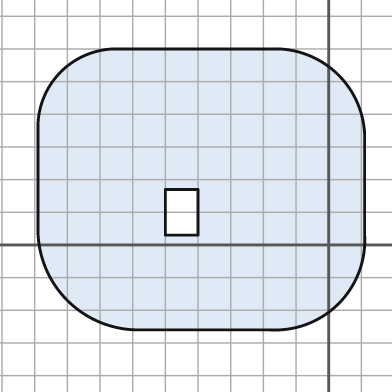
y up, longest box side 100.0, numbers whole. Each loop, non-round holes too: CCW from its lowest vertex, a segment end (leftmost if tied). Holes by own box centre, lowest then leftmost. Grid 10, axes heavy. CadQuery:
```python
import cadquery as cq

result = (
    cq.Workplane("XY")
    .moveTo(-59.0, -26.0)
    .lineTo(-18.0, -26.0)
    .threePointArc((3.0, -18.0), (11.0, 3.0))
    .lineTo(11.0, 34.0)
    .threePointArc((3.0, 52.0), (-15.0, 60.0))
    .lineTo(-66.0, 60.0)
    .threePointArc((-82.0, 53.0), (-89.0, 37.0))
    .lineTo(-89.0, 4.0)
    .threePointArc((-80.0, -17.0), (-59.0, -26.0))
    .close()
    .moveTo(-50.0, 3.0)
    .lineTo(-40.0, 3.0)
    .lineTo(-40.0, 17.0)
    .lineTo(-50.0, 17.0)
    .close()
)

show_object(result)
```